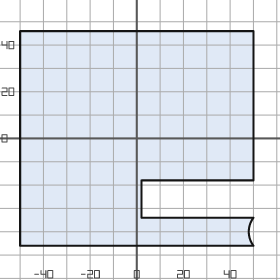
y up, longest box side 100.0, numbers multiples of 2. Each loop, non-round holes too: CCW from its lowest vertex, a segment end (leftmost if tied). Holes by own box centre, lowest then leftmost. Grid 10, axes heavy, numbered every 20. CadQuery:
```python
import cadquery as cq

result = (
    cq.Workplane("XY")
    .moveTo(-50.0, -46.0)
    .lineTo(50.0, -46.0)
    .threePointArc((48.0, -40.0), (50.0, -34.0))
    .lineTo(2.0, -34.0)
    .lineTo(2.0, -18.0)
    .lineTo(50.0, -18.0)
    .lineTo(50.0, 46.0)
    .lineTo(-50.0, 46.0)
    .close()
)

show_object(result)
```